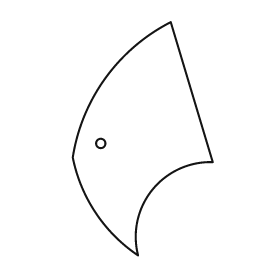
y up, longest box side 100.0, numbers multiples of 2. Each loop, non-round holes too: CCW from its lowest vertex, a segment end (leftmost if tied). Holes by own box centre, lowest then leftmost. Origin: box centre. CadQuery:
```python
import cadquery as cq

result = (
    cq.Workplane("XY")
    .moveTo(-2.0, -50.0)
    .threePointArc((4.0, -22.0), (30.0, -10.0))
    .lineTo(12.0, 50.0)
    .threePointArc((-16.0, 26.0), (-30.0, -8.0))
    .threePointArc((-20.0, -32.0), (-2.0, -50.0))
    .close()
    .moveTo(-18.0, -2.0)
    .circle(2.0)
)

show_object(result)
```